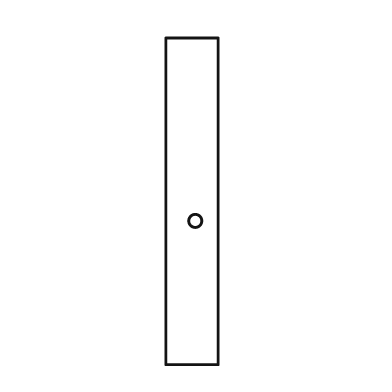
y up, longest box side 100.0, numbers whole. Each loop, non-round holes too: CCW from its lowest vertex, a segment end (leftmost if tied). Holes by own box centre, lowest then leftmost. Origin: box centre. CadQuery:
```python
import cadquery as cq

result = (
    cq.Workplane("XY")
    .moveTo(-8.0, -50.0)
    .lineTo(8.0, -50.0)
    .lineTo(8.0, 50.0)
    .lineTo(-8.0, 50.0)
    .close()
    .moveTo(1.0, -6.0)
    .circle(2.0)
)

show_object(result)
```